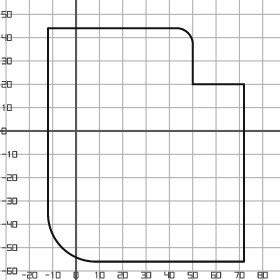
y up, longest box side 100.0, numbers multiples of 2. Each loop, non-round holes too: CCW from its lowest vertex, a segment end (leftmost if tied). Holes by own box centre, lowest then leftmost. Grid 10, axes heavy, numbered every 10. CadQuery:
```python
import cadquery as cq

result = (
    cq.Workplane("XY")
    .moveTo(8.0, -56.0)
    .lineTo(72.0, -56.0)
    .lineTo(72.0, 20.0)
    .lineTo(50.0, 20.0)
    .lineTo(50.0, 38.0)
    .threePointArc((48.0, 42.0), (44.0, 44.0))
    .lineTo(-12.0, 44.0)
    .lineTo(-12.0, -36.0)
    .threePointArc((-6.0, -50.0), (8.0, -56.0))
    .close()
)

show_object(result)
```